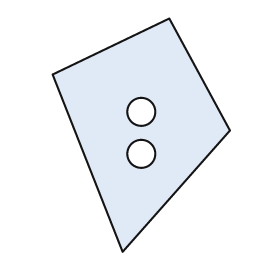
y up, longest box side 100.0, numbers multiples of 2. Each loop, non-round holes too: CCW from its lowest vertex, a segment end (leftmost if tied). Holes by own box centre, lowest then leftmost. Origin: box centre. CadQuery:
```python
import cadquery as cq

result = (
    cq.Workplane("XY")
    .moveTo(-8.0, -50.0)
    .lineTo(38.0, 2.0)
    .lineTo(12.0, 50.0)
    .lineTo(-38.0, 26.0)
    .close()
    .moveTo(0.0, -8.0)
    .circle(6.0)
    .moveTo(0.0, 10.0)
    .circle(6.0)
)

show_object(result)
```